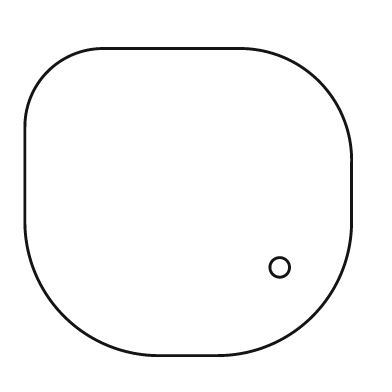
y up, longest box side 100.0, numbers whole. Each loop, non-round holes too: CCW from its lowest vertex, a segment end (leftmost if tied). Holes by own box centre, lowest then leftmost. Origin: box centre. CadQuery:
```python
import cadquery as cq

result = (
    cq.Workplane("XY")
    .moveTo(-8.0, -47.0)
    .lineTo(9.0, -47.0)
    .threePointArc((38.0, -35.0), (50.0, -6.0))
    .lineTo(50.0, 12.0)
    .threePointArc((40.0, 37.0), (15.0, 47.0))
    .lineTo(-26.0, 47.0)
    .threePointArc((-43.0, 40.0), (-50.0, 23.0))
    .lineTo(-50.0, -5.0)
    .threePointArc((-38.0, -35.0), (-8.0, -47.0))
    .close()
    .moveTo(28.0, -20.0)
    .circle(3.0)
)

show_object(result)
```